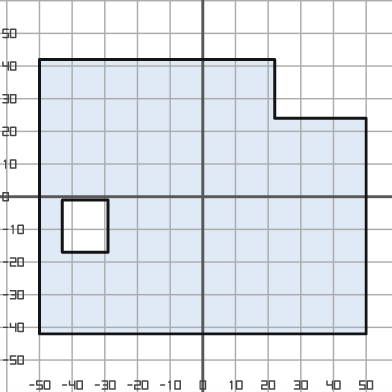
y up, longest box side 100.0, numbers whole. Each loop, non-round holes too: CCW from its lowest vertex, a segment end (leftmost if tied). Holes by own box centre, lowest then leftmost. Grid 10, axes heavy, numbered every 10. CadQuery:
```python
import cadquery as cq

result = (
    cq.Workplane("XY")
    .moveTo(-50.0, -42.0)
    .lineTo(50.0, -42.0)
    .lineTo(50.0, 24.0)
    .lineTo(22.0, 24.0)
    .lineTo(22.0, 42.0)
    .lineTo(-50.0, 42.0)
    .close()
    .moveTo(-43.0, -17.0)
    .lineTo(-29.0, -17.0)
    .lineTo(-29.0, -1.0)
    .lineTo(-43.0, -1.0)
    .close()
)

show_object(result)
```